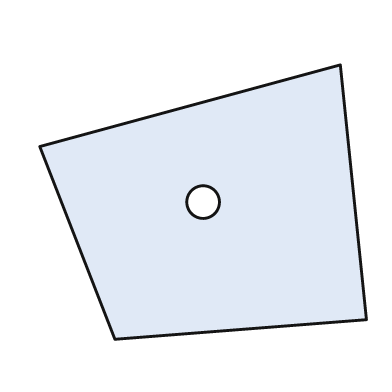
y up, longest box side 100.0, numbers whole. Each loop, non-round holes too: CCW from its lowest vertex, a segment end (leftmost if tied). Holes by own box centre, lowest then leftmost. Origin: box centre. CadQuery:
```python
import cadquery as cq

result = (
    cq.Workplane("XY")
    .moveTo(-27.0, -42.0)
    .lineTo(50.0, -36.0)
    .lineTo(42.0, 42.0)
    .lineTo(-50.0, 17.0)
    .close()
    .moveTo(0.0, 0.0)
    .circle(5.0)
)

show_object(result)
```